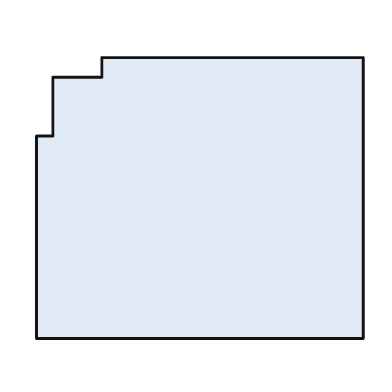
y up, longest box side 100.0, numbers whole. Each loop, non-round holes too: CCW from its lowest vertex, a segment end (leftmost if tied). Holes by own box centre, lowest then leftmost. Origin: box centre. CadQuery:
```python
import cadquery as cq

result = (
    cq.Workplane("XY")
    .moveTo(-50.0, -43.0)
    .lineTo(50.0, -43.0)
    .lineTo(50.0, 43.0)
    .lineTo(-30.0, 43.0)
    .lineTo(-30.0, 37.0)
    .lineTo(-45.0, 37.0)
    .lineTo(-45.0, 19.0)
    .lineTo(-50.0, 19.0)
    .close()
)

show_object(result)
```